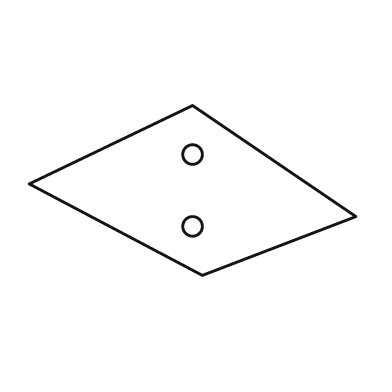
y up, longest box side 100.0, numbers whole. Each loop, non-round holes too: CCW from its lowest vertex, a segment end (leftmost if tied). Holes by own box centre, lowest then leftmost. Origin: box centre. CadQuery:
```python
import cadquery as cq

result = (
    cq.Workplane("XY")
    .moveTo(3.0, -26.0)
    .lineTo(50.0, -8.0)
    .lineTo(0.0, 26.0)
    .lineTo(-50.0, 2.0)
    .close()
    .moveTo(0.0, -11.0)
    .circle(3.0)
    .moveTo(0.0, 11.0)
    .circle(3.0)
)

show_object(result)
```